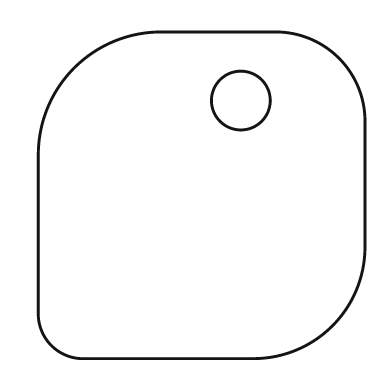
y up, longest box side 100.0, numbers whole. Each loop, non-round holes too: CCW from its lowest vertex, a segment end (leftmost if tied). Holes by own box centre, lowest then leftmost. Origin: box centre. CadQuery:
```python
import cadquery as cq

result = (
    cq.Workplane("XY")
    .moveTo(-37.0, -50.0)
    .lineTo(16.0, -50.0)
    .threePointArc((40.0, -40.0), (50.0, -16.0))
    .lineTo(50.0, 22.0)
    .threePointArc((42.0, 42.0), (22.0, 50.0))
    .lineTo(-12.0, 50.0)
    .threePointArc((-39.0, 39.0), (-50.0, 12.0))
    .lineTo(-50.0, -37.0)
    .threePointArc((-46.0, -46.0), (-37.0, -50.0))
    .close()
    .moveTo(12.0, 29.0)
    .circle(9.0)
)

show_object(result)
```